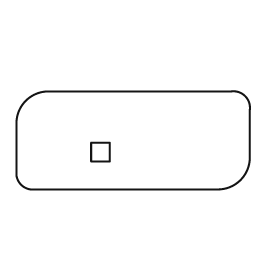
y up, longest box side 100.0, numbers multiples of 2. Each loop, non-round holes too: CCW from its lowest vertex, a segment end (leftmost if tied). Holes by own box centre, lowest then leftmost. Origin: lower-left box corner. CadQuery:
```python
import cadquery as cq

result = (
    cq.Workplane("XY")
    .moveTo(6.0, 0.0)
    .lineTo(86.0, 0.0)
    .threePointArc((96.0, 4.0), (100.0, 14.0))
    .lineTo(100.0, 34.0)
    .threePointArc((98.0, 40.0), (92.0, 42.0))
    .lineTo(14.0, 42.0)
    .threePointArc((4.0, 38.0), (0.0, 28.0))
    .lineTo(0.0, 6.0)
    .threePointArc((2.0, 2.0), (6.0, 0.0))
    .close()
    .moveTo(32.0, 12.0)
    .lineTo(40.0, 12.0)
    .lineTo(40.0, 20.0)
    .lineTo(32.0, 20.0)
    .close()
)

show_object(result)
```